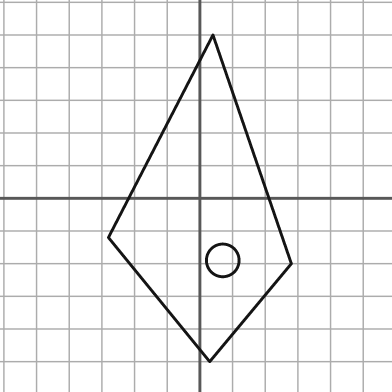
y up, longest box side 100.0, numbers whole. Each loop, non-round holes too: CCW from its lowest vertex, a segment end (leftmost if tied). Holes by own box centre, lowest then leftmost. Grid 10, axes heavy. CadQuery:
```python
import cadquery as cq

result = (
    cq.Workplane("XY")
    .moveTo(3.0, -50.0)
    .lineTo(28.0, -20.0)
    .lineTo(4.0, 50.0)
    .lineTo(-28.0, -12.0)
    .close()
    .moveTo(7.0, -19.0)
    .circle(5.0)
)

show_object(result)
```